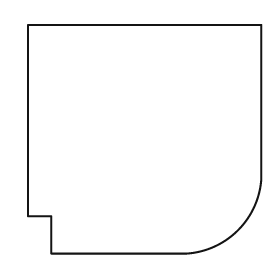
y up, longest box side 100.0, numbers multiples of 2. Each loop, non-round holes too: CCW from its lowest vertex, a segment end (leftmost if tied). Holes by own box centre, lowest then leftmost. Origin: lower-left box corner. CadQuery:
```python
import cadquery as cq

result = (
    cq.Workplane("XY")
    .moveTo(10.0, 0.0)
    .lineTo(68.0, 0.0)
    .threePointArc((90.0, 10.0), (100.0, 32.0))
    .lineTo(100.0, 98.0)
    .lineTo(0.0, 98.0)
    .lineTo(0.0, 16.0)
    .lineTo(10.0, 16.0)
    .close()
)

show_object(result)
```